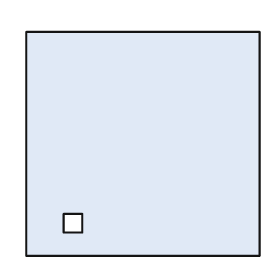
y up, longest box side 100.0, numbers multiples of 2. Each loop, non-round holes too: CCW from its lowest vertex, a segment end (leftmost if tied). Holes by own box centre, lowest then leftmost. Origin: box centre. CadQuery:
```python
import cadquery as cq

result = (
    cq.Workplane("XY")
    .moveTo(-50.0, -48.0)
    .lineTo(50.0, -48.0)
    .lineTo(50.0, 48.0)
    .lineTo(-50.0, 48.0)
    .close()
    .moveTo(-34.0, -38.0)
    .lineTo(-26.0, -38.0)
    .lineTo(-26.0, -30.0)
    .lineTo(-34.0, -30.0)
    .close()
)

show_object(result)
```